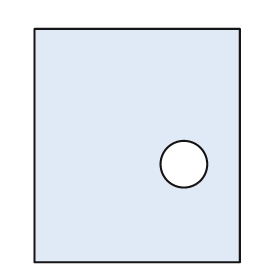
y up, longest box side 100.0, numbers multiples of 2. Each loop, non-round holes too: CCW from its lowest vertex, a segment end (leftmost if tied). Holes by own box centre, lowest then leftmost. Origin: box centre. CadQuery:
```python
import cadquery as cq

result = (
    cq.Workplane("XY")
    .moveTo(-44.0, -50.0)
    .lineTo(44.0, -50.0)
    .lineTo(44.0, 50.0)
    .lineTo(-44.0, 50.0)
    .close()
    .moveTo(20.0, -8.0)
    .circle(10.0)
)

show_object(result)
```